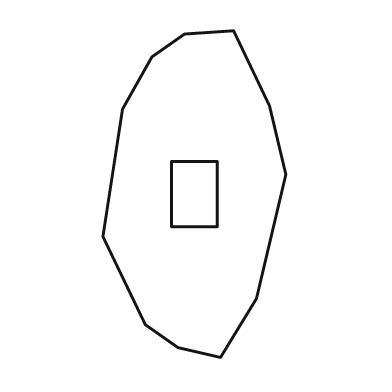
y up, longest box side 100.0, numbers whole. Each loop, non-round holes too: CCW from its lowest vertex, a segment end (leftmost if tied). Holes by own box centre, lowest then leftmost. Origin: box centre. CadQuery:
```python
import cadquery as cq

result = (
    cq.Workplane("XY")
    .moveTo(8.0, -50.0)
    .lineTo(19.0, -32.0)
    .lineTo(28.0, 6.0)
    .lineTo(23.0, 27.0)
    .lineTo(12.0, 50.0)
    .lineTo(-3.0, 49.0)
    .lineTo(-13.0, 42.0)
    .lineTo(-22.0, 26.0)
    .lineTo(-28.0, -13.0)
    .lineTo(-15.0, -40.0)
    .lineTo(-5.0, -47.0)
    .close()
    .moveTo(-7.0, -10.0)
    .lineTo(7.0, -10.0)
    .lineTo(7.0, 10.0)
    .lineTo(-7.0, 10.0)
    .close()
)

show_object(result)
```